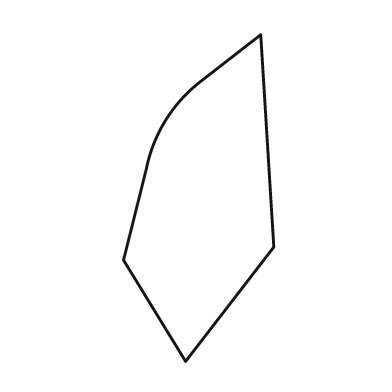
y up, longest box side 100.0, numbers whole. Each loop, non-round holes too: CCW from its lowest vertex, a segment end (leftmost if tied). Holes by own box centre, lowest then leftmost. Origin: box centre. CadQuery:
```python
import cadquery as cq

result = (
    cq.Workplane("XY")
    .moveTo(-4.0, -50.0)
    .lineTo(23.0, -15.0)
    .lineTo(19.0, 50.0)
    .lineTo(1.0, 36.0)
    .threePointArc((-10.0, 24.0), (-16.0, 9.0))
    .lineTo(-23.0, -19.0)
    .close()
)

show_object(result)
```